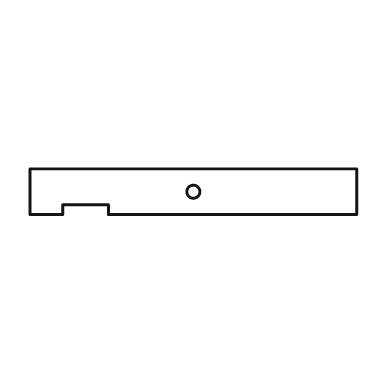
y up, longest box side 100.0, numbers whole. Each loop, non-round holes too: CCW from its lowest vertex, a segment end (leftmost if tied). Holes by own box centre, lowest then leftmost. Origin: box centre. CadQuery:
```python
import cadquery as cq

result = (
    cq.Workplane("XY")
    .moveTo(-50.0, -7.0)
    .lineTo(-40.0, -7.0)
    .lineTo(-40.0, -4.0)
    .lineTo(-26.0, -4.0)
    .lineTo(-26.0, -7.0)
    .lineTo(50.0, -7.0)
    .lineTo(50.0, 7.0)
    .lineTo(-50.0, 7.0)
    .close()
    .moveTo(0.0, 0.0)
    .circle(2.0)
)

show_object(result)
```